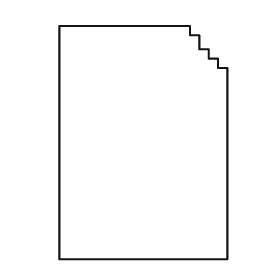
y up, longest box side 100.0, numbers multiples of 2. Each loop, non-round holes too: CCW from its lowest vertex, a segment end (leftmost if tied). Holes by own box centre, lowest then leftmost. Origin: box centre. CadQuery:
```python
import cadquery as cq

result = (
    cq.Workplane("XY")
    .moveTo(-36.0, -50.0)
    .lineTo(36.0, -50.0)
    .lineTo(36.0, 32.0)
    .lineTo(32.0, 32.0)
    .lineTo(32.0, 36.0)
    .lineTo(28.0, 36.0)
    .lineTo(28.0, 40.0)
    .lineTo(24.0, 40.0)
    .lineTo(24.0, 46.0)
    .lineTo(20.0, 46.0)
    .lineTo(20.0, 50.0)
    .lineTo(-36.0, 50.0)
    .close()
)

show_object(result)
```